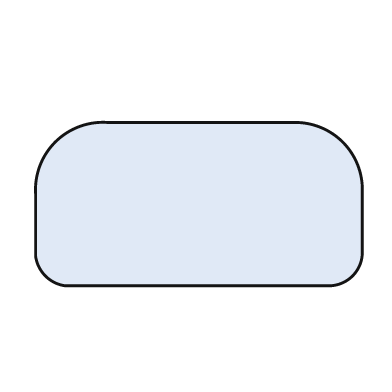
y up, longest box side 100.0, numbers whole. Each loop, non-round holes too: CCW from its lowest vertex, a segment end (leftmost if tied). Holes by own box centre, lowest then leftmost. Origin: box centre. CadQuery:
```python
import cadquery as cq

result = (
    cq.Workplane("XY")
    .moveTo(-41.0, -25.0)
    .lineTo(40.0, -25.0)
    .threePointArc((47.0, -22.0), (50.0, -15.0))
    .lineTo(50.0, 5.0)
    .threePointArc((44.0, 19.0), (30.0, 25.0))
    .lineTo(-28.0, 25.0)
    .threePointArc((-44.0, 19.0), (-50.0, 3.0))
    .lineTo(-50.0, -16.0)
    .threePointArc((-47.0, -22.0), (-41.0, -25.0))
    .close()
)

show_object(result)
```